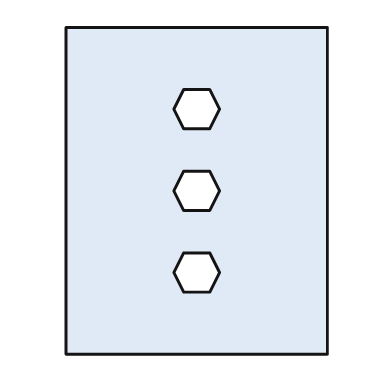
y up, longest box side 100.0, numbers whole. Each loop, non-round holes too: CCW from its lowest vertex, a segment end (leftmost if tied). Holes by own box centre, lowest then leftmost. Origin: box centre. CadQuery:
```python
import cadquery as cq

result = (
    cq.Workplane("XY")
    .moveTo(-40.0, -50.0)
    .lineTo(40.0, -50.0)
    .lineTo(40.0, 50.0)
    .lineTo(-40.0, 50.0)
    .close()
    .moveTo(-4.0, -31.0)
    .lineTo(4.0, -31.0)
    .lineTo(7.0, -25.0)
    .lineTo(4.0, -19.0)
    .lineTo(-4.0, -19.0)
    .lineTo(-7.0, -25.0)
    .close()
    .moveTo(-4.0, -6.0)
    .lineTo(4.0, -6.0)
    .lineTo(7.0, 0.0)
    .lineTo(4.0, 6.0)
    .lineTo(-4.0, 6.0)
    .lineTo(-7.0, 0.0)
    .close()
    .moveTo(-4.0, 19.0)
    .lineTo(4.0, 19.0)
    .lineTo(7.0, 25.0)
    .lineTo(4.0, 31.0)
    .lineTo(-4.0, 31.0)
    .lineTo(-7.0, 25.0)
    .close()
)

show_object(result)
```